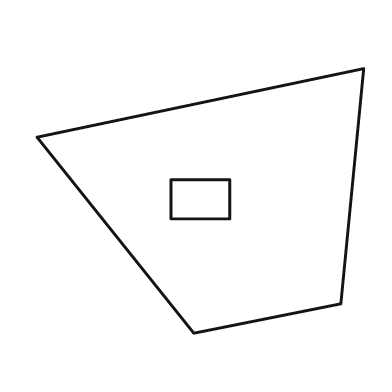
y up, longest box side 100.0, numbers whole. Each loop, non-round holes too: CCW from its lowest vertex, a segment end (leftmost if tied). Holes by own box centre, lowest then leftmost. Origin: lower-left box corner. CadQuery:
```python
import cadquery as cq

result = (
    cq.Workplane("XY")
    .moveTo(48.0, 0.0)
    .lineTo(93.0, 9.0)
    .lineTo(100.0, 81.0)
    .lineTo(0.0, 60.0)
    .close()
    .moveTo(41.0, 35.0)
    .lineTo(59.0, 35.0)
    .lineTo(59.0, 47.0)
    .lineTo(41.0, 47.0)
    .close()
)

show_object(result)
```